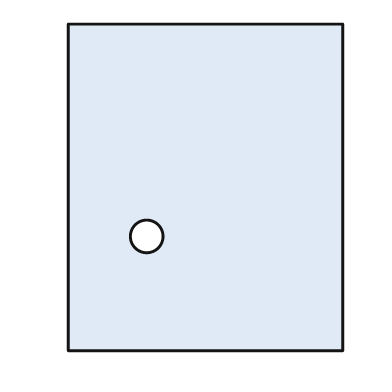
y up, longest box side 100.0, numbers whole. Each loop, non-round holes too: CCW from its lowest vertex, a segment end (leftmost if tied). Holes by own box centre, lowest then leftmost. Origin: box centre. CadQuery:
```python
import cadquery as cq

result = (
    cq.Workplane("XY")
    .moveTo(-42.0, -50.0)
    .lineTo(42.0, -50.0)
    .lineTo(42.0, 50.0)
    .lineTo(-42.0, 50.0)
    .close()
    .moveTo(-18.0, -15.0)
    .circle(5.0)
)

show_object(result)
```